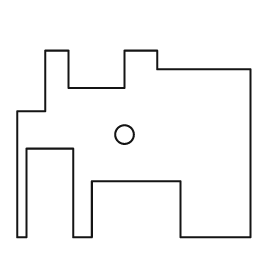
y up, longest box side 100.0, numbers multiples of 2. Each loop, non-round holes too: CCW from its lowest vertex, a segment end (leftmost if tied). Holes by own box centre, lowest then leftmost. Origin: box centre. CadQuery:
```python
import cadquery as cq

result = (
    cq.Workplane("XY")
    .moveTo(-50.0, -40.0)
    .lineTo(-46.0, -40.0)
    .lineTo(-46.0, -2.0)
    .lineTo(-26.0, -2.0)
    .lineTo(-26.0, -40.0)
    .lineTo(-18.0, -40.0)
    .lineTo(-18.0, -16.0)
    .lineTo(20.0, -16.0)
    .lineTo(20.0, -40.0)
    .lineTo(50.0, -40.0)
    .lineTo(50.0, 32.0)
    .lineTo(10.0, 32.0)
    .lineTo(10.0, 40.0)
    .lineTo(-4.0, 40.0)
    .lineTo(-4.0, 24.0)
    .lineTo(-28.0, 24.0)
    .lineTo(-28.0, 40.0)
    .lineTo(-38.0, 40.0)
    .lineTo(-38.0, 14.0)
    .lineTo(-50.0, 14.0)
    .close()
    .moveTo(-4.0, 4.0)
    .circle(4.0)
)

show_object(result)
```